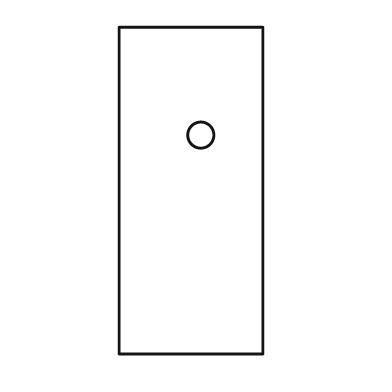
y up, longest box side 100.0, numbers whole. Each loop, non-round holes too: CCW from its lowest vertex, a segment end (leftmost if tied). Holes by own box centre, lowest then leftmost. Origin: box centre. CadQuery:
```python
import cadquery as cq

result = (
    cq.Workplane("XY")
    .moveTo(-22.0, -50.0)
    .lineTo(22.0, -50.0)
    .lineTo(22.0, 50.0)
    .lineTo(-22.0, 50.0)
    .close()
    .moveTo(3.0, 17.0)
    .circle(4.0)
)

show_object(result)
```